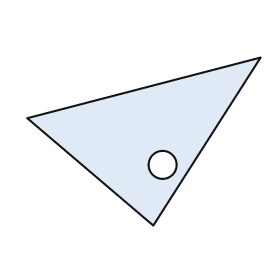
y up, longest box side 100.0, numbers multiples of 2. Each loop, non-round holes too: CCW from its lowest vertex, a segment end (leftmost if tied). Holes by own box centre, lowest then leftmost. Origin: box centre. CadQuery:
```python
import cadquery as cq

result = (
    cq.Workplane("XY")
    .moveTo(4.0, -36.0)
    .lineTo(50.0, 36.0)
    .lineTo(-50.0, 10.0)
    .close()
    .moveTo(8.0, -10.0)
    .circle(6.0)
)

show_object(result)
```